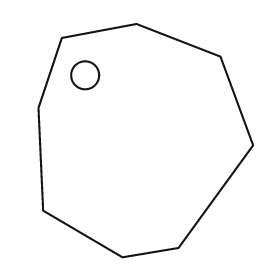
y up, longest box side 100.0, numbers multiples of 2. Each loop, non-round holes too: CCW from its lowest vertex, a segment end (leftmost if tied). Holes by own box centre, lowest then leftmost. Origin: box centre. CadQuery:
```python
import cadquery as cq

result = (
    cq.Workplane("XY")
    .moveTo(-10.0, -50.0)
    .lineTo(14.0, -46.0)
    .lineTo(46.0, -2.0)
    .lineTo(32.0, 36.0)
    .lineTo(-4.0, 50.0)
    .lineTo(-36.0, 44.0)
    .lineTo(-46.0, 14.0)
    .lineTo(-44.0, -30.0)
    .close()
    .moveTo(-26.0, 28.0)
    .circle(6.0)
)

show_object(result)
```